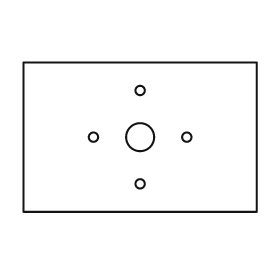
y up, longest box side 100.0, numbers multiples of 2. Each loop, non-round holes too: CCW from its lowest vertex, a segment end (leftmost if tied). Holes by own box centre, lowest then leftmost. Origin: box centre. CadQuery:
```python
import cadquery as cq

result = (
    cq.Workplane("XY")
    .moveTo(-50.0, -32.0)
    .lineTo(50.0, -32.0)
    .lineTo(50.0, 32.0)
    .lineTo(-50.0, 32.0)
    .close()
    .moveTo(0.0, -20.0)
    .circle(2.0)
    .moveTo(-20.0, 0.0)
    .circle(2.0)
    .moveTo(0.0, 0.0)
    .circle(6.0)
    .moveTo(20.0, 0.0)
    .circle(2.0)
    .moveTo(0.0, 20.0)
    .circle(2.0)
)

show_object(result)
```